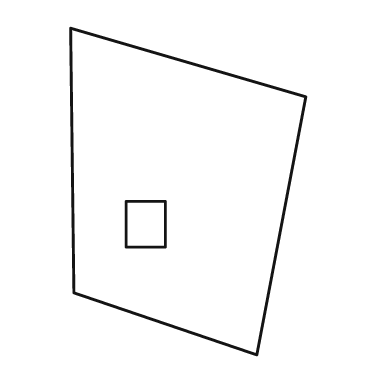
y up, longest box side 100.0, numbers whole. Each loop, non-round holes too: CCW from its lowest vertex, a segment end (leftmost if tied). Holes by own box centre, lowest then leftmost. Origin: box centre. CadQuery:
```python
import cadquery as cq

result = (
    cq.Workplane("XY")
    .moveTo(21.0, -50.0)
    .lineTo(36.0, 29.0)
    .lineTo(-36.0, 50.0)
    .lineTo(-35.0, -31.0)
    .close()
    .moveTo(-19.0, -17.0)
    .lineTo(-7.0, -17.0)
    .lineTo(-7.0, -3.0)
    .lineTo(-19.0, -3.0)
    .close()
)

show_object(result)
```